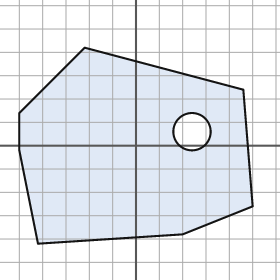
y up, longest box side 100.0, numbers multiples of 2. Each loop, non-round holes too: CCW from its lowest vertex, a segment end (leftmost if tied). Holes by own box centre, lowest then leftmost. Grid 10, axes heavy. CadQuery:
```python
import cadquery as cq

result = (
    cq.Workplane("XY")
    .moveTo(-42.0, -42.0)
    .lineTo(20.0, -38.0)
    .lineTo(50.0, -26.0)
    .lineTo(46.0, 24.0)
    .lineTo(-22.0, 42.0)
    .lineTo(-50.0, 14.0)
    .lineTo(-50.0, -2.0)
    .close()
    .moveTo(24.0, 6.0)
    .circle(8.0)
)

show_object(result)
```